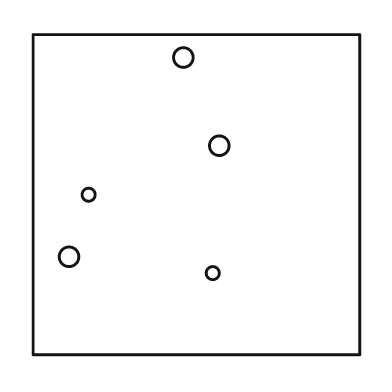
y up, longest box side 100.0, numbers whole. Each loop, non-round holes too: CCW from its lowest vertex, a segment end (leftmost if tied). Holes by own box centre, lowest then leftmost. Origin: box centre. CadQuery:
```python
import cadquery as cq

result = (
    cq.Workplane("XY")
    .moveTo(-50.0, -49.0)
    .lineTo(50.0, -49.0)
    .lineTo(50.0, 49.0)
    .lineTo(-50.0, 49.0)
    .close()
    .moveTo(5.0, -24.0)
    .circle(2.0)
    .moveTo(-39.0, -19.0)
    .circle(3.0)
    .moveTo(-33.0, 0.0)
    .circle(2.0)
    .moveTo(7.0, 15.0)
    .circle(3.0)
    .moveTo(-4.0, 42.0)
    .circle(3.0)
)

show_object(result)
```